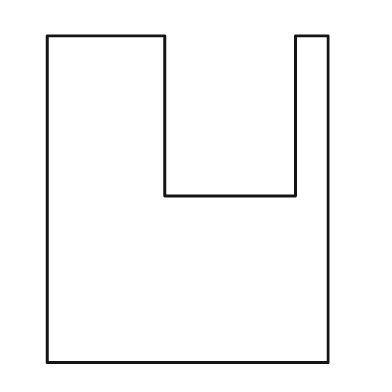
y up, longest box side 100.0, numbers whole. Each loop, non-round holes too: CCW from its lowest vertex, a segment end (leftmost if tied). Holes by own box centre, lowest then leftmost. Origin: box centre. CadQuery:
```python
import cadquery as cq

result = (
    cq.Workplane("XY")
    .moveTo(-43.0, -50.0)
    .lineTo(43.0, -50.0)
    .lineTo(43.0, 50.0)
    .lineTo(33.0, 50.0)
    .lineTo(33.0, 1.0)
    .lineTo(-7.0, 1.0)
    .lineTo(-7.0, 50.0)
    .lineTo(-43.0, 50.0)
    .close()
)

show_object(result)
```